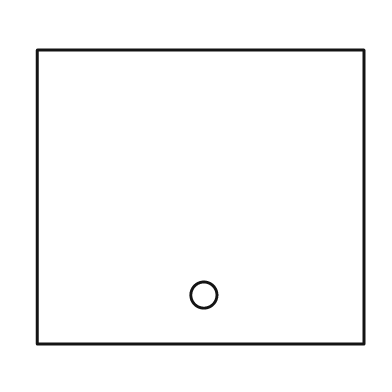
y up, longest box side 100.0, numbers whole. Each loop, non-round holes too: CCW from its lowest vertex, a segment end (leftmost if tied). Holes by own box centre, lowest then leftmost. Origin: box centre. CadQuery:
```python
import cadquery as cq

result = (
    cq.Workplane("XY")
    .moveTo(-50.0, -45.0)
    .lineTo(50.0, -45.0)
    .lineTo(50.0, 45.0)
    .lineTo(-50.0, 45.0)
    .close()
    .moveTo(1.0, -30.0)
    .circle(4.0)
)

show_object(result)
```